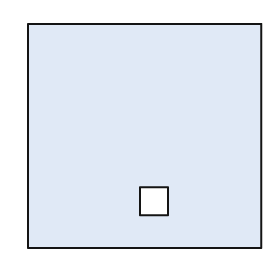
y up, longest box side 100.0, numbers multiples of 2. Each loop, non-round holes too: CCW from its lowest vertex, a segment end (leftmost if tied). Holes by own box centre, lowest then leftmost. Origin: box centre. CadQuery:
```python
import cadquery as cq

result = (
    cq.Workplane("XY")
    .moveTo(-50.0, -48.0)
    .lineTo(50.0, -48.0)
    .lineTo(50.0, 48.0)
    .lineTo(-50.0, 48.0)
    .close()
    .moveTo(-2.0, -34.0)
    .lineTo(10.0, -34.0)
    .lineTo(10.0, -22.0)
    .lineTo(-2.0, -22.0)
    .close()
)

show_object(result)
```